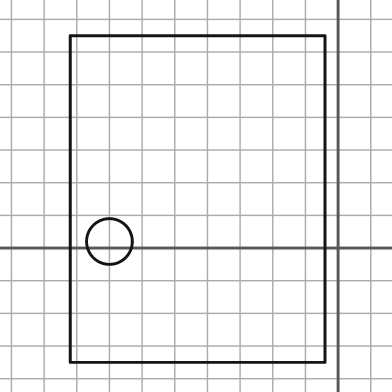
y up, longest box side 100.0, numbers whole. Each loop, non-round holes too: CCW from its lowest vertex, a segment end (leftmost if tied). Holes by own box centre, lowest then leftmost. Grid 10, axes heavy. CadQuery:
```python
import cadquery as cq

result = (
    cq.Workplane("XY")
    .moveTo(-82.0, -35.0)
    .lineTo(-4.0, -35.0)
    .lineTo(-4.0, 65.0)
    .lineTo(-82.0, 65.0)
    .close()
    .moveTo(-70.0, 2.0)
    .circle(7.0)
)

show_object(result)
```